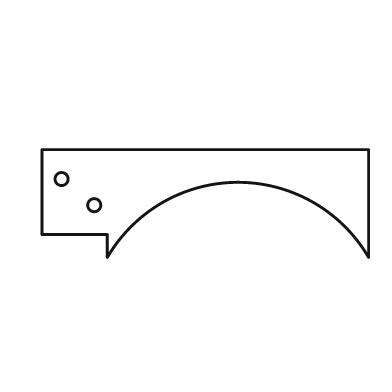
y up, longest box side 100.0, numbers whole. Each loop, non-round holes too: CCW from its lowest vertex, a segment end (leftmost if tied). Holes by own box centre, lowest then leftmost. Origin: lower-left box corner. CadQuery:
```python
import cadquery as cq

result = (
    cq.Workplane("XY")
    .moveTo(20.0, 0.0)
    .threePointArc((60.0, 23.0), (100.0, 0.0))
    .lineTo(100.0, 33.0)
    .lineTo(0.0, 33.0)
    .lineTo(0.0, 7.0)
    .lineTo(20.0, 7.0)
    .close()
    .moveTo(16.0, 16.0)
    .circle(2.0)
    .moveTo(6.0, 24.0)
    .circle(2.0)
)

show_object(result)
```